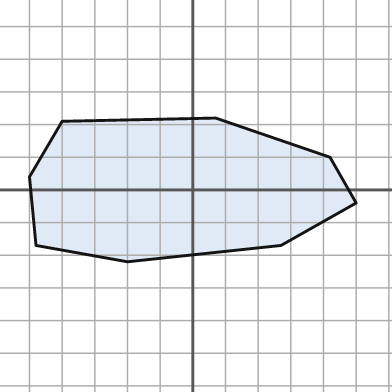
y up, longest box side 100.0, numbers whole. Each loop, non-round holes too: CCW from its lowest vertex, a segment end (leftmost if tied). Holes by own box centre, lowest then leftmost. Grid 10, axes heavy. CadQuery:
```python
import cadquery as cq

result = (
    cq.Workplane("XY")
    .moveTo(-20.0, -22.0)
    .lineTo(27.0, -17.0)
    .lineTo(50.0, -4.0)
    .lineTo(42.0, 10.0)
    .lineTo(7.0, 22.0)
    .lineTo(-40.0, 21.0)
    .lineTo(-50.0, 4.0)
    .lineTo(-48.0, -17.0)
    .close()
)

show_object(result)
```